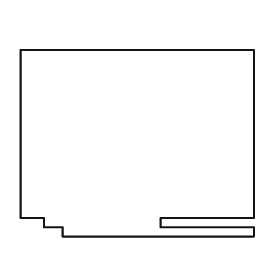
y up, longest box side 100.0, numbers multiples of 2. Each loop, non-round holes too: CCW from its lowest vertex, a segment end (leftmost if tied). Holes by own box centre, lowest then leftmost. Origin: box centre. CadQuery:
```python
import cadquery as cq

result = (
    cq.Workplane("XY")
    .moveTo(-32.0, -40.0)
    .lineTo(50.0, -40.0)
    .lineTo(50.0, -36.0)
    .lineTo(10.0, -36.0)
    .lineTo(10.0, -32.0)
    .lineTo(50.0, -32.0)
    .lineTo(50.0, 40.0)
    .lineTo(-50.0, 40.0)
    .lineTo(-50.0, -32.0)
    .lineTo(-40.0, -32.0)
    .lineTo(-40.0, -36.0)
    .lineTo(-32.0, -36.0)
    .close()
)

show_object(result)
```